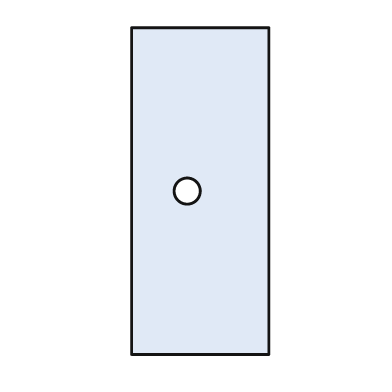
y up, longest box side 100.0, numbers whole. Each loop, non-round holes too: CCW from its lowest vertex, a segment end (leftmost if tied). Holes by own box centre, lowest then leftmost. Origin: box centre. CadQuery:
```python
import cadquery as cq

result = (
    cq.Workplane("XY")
    .moveTo(-21.0, -50.0)
    .lineTo(21.0, -50.0)
    .lineTo(21.0, 50.0)
    .lineTo(-21.0, 50.0)
    .close()
    .moveTo(-4.0, 0.0)
    .circle(4.0)
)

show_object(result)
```